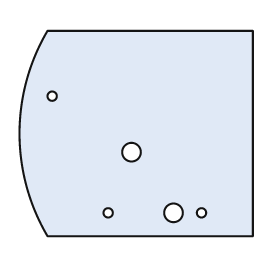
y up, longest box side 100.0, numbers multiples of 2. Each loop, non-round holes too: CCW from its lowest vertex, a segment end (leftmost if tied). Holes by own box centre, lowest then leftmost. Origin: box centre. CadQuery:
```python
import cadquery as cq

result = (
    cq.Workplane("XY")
    .moveTo(-38.0, -44.0)
    .lineTo(50.0, -44.0)
    .lineTo(50.0, 44.0)
    .lineTo(-38.0, 44.0)
    .threePointArc((-50.0, 0.0), (-38.0, -44.0))
    .close()
    .moveTo(-12.0, -34.0)
    .circle(2.0)
    .moveTo(16.0, -34.0)
    .circle(4.0)
    .moveTo(28.0, -34.0)
    .circle(2.0)
    .moveTo(-2.0, -8.0)
    .circle(4.0)
    .moveTo(-36.0, 16.0)
    .circle(2.0)
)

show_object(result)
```